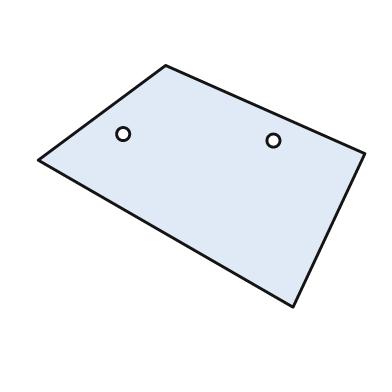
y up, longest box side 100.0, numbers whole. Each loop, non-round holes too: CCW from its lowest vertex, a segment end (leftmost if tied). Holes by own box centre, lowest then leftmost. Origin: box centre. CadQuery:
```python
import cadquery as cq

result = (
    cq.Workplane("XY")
    .moveTo(28.0, -37.0)
    .lineTo(50.0, 10.0)
    .lineTo(-11.0, 37.0)
    .lineTo(-50.0, 8.0)
    .close()
    .moveTo(22.0, 14.0)
    .circle(2.0)
    .moveTo(-24.0, 16.0)
    .circle(2.0)
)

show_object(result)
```